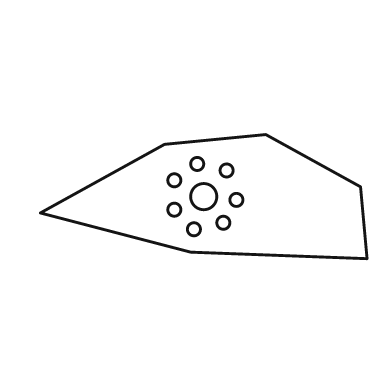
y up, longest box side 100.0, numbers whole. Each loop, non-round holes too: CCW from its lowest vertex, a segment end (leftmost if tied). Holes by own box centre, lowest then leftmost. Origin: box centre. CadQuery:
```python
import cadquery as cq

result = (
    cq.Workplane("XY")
    .moveTo(50.0, -19.0)
    .lineTo(48.0, 3.0)
    .lineTo(19.0, 19.0)
    .lineTo(-12.0, 16.0)
    .lineTo(-50.0, -5.0)
    .lineTo(-4.0, -17.0)
    .close()
    .moveTo(-3.0, -10.0)
    .circle(2.0)
    .moveTo(6.0, -8.0)
    .circle(2.0)
    .moveTo(-9.0, -4.0)
    .circle(2.0)
    .moveTo(10.0, -1.0)
    .circle(2.0)
    .moveTo(0.0, 0.0)
    .circle(4.0)
    .moveTo(-9.0, 5.0)
    .circle(2.0)
    .moveTo(7.0, 8.0)
    .circle(2.0)
    .moveTo(-2.0, 10.0)
    .circle(2.0)
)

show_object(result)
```